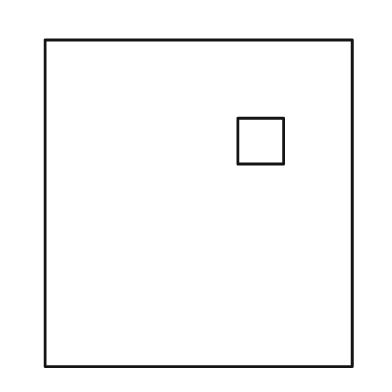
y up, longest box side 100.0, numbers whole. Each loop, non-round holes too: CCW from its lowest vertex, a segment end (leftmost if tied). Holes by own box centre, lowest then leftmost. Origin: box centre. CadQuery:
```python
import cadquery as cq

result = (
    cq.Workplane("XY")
    .moveTo(-47.0, -50.0)
    .lineTo(47.0, -50.0)
    .lineTo(47.0, 50.0)
    .lineTo(-47.0, 50.0)
    .close()
    .moveTo(12.0, 12.0)
    .lineTo(26.0, 12.0)
    .lineTo(26.0, 26.0)
    .lineTo(12.0, 26.0)
    .close()
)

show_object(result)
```